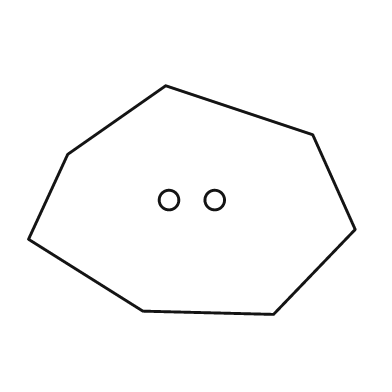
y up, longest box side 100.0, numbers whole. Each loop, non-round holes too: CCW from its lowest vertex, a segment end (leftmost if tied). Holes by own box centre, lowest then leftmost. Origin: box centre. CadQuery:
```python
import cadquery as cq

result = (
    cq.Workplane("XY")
    .moveTo(25.0, -35.0)
    .lineTo(50.0, -9.0)
    .lineTo(37.0, 20.0)
    .lineTo(-8.0, 35.0)
    .lineTo(-38.0, 14.0)
    .lineTo(-50.0, -12.0)
    .lineTo(-15.0, -34.0)
    .close()
    .moveTo(-7.0, 0.0)
    .circle(3.0)
    .moveTo(7.0, 0.0)
    .circle(3.0)
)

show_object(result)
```